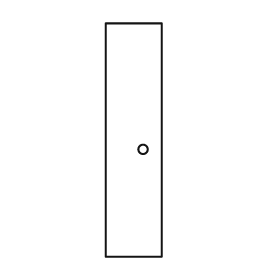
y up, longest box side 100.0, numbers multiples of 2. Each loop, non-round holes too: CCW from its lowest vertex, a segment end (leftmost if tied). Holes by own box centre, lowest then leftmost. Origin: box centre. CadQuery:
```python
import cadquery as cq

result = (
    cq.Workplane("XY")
    .moveTo(-12.0, -50.0)
    .lineTo(12.0, -50.0)
    .lineTo(12.0, 50.0)
    .lineTo(-12.0, 50.0)
    .close()
    .moveTo(4.0, -4.0)
    .circle(2.0)
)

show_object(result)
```